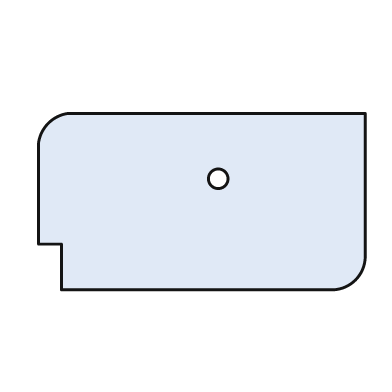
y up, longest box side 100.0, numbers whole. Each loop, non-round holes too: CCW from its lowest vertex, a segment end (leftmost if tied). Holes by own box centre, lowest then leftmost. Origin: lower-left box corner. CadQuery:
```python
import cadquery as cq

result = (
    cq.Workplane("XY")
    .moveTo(7.0, 0.0)
    .lineTo(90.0, 0.0)
    .threePointArc((97.0, 3.0), (100.0, 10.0))
    .lineTo(100.0, 54.0)
    .lineTo(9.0, 54.0)
    .threePointArc((3.0, 51.0), (0.0, 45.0))
    .lineTo(0.0, 14.0)
    .lineTo(7.0, 14.0)
    .close()
    .moveTo(55.0, 34.0)
    .circle(3.0)
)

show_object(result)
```